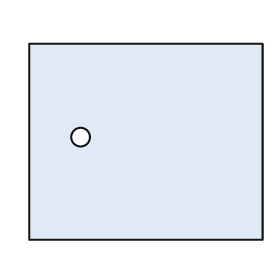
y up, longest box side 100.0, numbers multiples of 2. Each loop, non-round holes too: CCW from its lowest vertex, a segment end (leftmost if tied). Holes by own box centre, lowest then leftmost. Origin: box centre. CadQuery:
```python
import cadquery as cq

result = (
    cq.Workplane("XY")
    .moveTo(-50.0, -42.0)
    .lineTo(50.0, -42.0)
    .lineTo(50.0, 42.0)
    .lineTo(-50.0, 42.0)
    .close()
    .moveTo(-28.0, 2.0)
    .circle(4.0)
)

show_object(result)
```